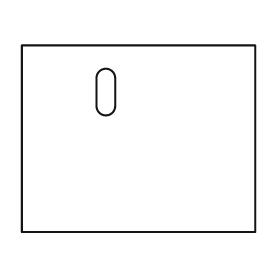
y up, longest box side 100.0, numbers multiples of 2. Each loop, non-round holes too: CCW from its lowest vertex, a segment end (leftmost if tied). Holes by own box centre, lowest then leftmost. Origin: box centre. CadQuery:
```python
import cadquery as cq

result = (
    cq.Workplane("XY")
    .moveTo(-50.0, -40.0)
    .lineTo(50.0, -40.0)
    .lineTo(50.0, 40.0)
    .lineTo(-50.0, 40.0)
    .close()
    .moveTo(-18.0, 14.0)
    .threePointArc((-14.0, 10.0), (-10.0, 14.0))
    .lineTo(-10.0, 26.0)
    .threePointArc((-14.0, 30.0), (-18.0, 26.0))
    .close()
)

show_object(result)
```